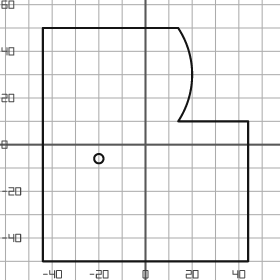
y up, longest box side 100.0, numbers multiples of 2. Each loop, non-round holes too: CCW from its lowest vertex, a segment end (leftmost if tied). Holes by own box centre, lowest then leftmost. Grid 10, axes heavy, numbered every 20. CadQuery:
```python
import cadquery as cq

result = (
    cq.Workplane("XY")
    .moveTo(-44.0, -50.0)
    .lineTo(44.0, -50.0)
    .lineTo(44.0, 10.0)
    .lineTo(14.0, 10.0)
    .threePointArc((20.0, 30.0), (14.0, 50.0))
    .lineTo(-44.0, 50.0)
    .close()
    .moveTo(-20.0, -6.0)
    .circle(2.0)
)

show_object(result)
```